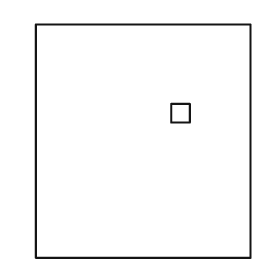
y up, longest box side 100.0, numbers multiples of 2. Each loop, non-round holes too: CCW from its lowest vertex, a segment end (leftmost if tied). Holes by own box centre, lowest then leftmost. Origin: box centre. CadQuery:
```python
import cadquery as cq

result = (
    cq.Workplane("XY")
    .moveTo(-46.0, -50.0)
    .lineTo(46.0, -50.0)
    .lineTo(46.0, 50.0)
    .lineTo(-46.0, 50.0)
    .close()
    .moveTo(12.0, 8.0)
    .lineTo(20.0, 8.0)
    .lineTo(20.0, 16.0)
    .lineTo(12.0, 16.0)
    .close()
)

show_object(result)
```